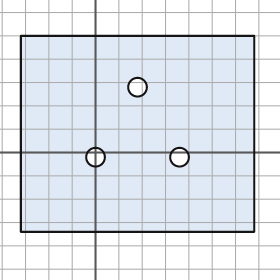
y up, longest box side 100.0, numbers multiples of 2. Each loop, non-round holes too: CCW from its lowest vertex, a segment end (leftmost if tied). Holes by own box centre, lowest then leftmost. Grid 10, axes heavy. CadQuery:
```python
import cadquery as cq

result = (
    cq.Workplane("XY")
    .moveTo(-32.0, -34.0)
    .lineTo(68.0, -34.0)
    .lineTo(68.0, 50.0)
    .lineTo(-32.0, 50.0)
    .close()
    .moveTo(0.0, -2.0)
    .circle(4.0)
    .moveTo(36.0, -2.0)
    .circle(4.0)
    .moveTo(18.0, 28.0)
    .circle(4.0)
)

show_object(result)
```